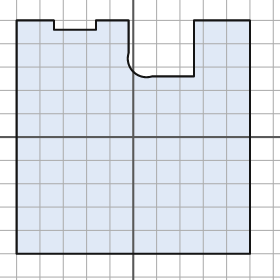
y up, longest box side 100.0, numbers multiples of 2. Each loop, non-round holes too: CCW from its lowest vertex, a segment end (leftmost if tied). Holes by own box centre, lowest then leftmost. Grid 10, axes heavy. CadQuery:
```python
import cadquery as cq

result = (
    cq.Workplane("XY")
    .moveTo(-50.0, -50.0)
    .lineTo(50.0, -50.0)
    .lineTo(50.0, 50.0)
    .lineTo(26.0, 50.0)
    .lineTo(26.0, 26.0)
    .lineTo(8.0, 26.0)
    .threePointArc((0.0, 28.0), (-2.0, 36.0))
    .lineTo(-2.0, 50.0)
    .lineTo(-16.0, 50.0)
    .lineTo(-16.0, 46.0)
    .lineTo(-34.0, 46.0)
    .lineTo(-34.0, 50.0)
    .lineTo(-50.0, 50.0)
    .close()
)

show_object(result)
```